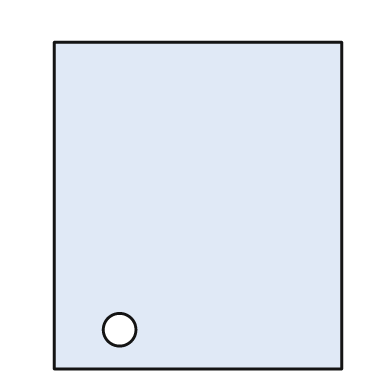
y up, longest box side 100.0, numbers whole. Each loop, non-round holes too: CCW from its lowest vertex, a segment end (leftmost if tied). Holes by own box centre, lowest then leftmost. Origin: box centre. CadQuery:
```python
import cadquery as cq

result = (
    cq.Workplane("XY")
    .moveTo(-44.0, -50.0)
    .lineTo(44.0, -50.0)
    .lineTo(44.0, 50.0)
    .lineTo(-44.0, 50.0)
    .close()
    .moveTo(-24.0, -38.0)
    .circle(5.0)
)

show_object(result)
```